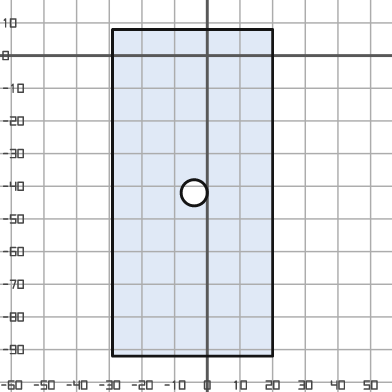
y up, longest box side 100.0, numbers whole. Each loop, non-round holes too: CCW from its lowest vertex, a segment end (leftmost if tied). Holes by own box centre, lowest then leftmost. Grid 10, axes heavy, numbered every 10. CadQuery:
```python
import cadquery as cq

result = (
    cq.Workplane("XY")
    .moveTo(-29.0, -92.0)
    .lineTo(20.0, -92.0)
    .lineTo(20.0, 8.0)
    .lineTo(-29.0, 8.0)
    .close()
    .moveTo(-4.0, -42.0)
    .circle(4.0)
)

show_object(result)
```